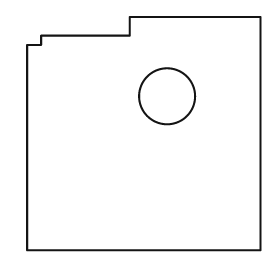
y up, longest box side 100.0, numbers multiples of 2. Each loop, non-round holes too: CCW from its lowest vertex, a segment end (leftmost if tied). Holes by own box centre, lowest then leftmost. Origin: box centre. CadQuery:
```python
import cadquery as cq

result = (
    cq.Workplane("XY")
    .moveTo(-50.0, -50.0)
    .lineTo(50.0, -50.0)
    .lineTo(50.0, 50.0)
    .lineTo(-6.0, 50.0)
    .lineTo(-6.0, 42.0)
    .lineTo(-44.0, 42.0)
    .lineTo(-44.0, 38.0)
    .lineTo(-50.0, 38.0)
    .close()
    .moveTo(10.0, 16.0)
    .circle(12.0)
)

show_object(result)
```